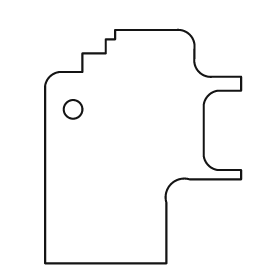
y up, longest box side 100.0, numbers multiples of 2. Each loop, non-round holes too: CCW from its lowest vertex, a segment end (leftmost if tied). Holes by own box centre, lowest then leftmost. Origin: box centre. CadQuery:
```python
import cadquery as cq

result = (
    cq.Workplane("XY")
    .moveTo(-42.0, -50.0)
    .lineTo(10.0, -50.0)
    .lineTo(10.0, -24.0)
    .threePointArc((12.0, -16.0), (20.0, -14.0))
    .lineTo(42.0, -14.0)
    .lineTo(42.0, -10.0)
    .lineTo(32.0, -10.0)
    .threePointArc((28.0, -8.0), (26.0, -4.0))
    .lineTo(26.0, 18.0)
    .threePointArc((28.0, 22.0), (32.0, 24.0))
    .lineTo(42.0, 24.0)
    .lineTo(42.0, 30.0)
    .lineTo(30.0, 30.0)
    .threePointArc((24.0, 32.0), (22.0, 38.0))
    .lineTo(22.0, 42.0)
    .threePointArc((20.0, 48.0), (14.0, 50.0))
    .lineTo(-12.0, 50.0)
    .lineTo(-12.0, 46.0)
    .lineTo(-16.0, 46.0)
    .lineTo(-16.0, 40.0)
    .lineTo(-26.0, 40.0)
    .lineTo(-26.0, 32.0)
    .lineTo(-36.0, 32.0)
    .threePointArc((-40.0, 30.0), (-42.0, 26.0))
    .close()
    .moveTo(-30.0, 16.0)
    .circle(4.0)
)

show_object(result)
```